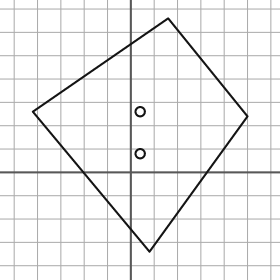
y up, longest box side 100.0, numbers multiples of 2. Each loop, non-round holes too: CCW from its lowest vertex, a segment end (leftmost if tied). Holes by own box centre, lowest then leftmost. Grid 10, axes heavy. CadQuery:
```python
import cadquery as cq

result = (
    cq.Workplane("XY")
    .moveTo(8.0, -34.0)
    .lineTo(50.0, 24.0)
    .lineTo(16.0, 66.0)
    .lineTo(-42.0, 26.0)
    .close()
    .moveTo(4.0, 8.0)
    .circle(2.0)
    .moveTo(4.0, 26.0)
    .circle(2.0)
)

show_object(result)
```